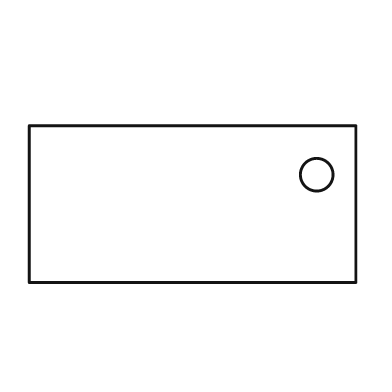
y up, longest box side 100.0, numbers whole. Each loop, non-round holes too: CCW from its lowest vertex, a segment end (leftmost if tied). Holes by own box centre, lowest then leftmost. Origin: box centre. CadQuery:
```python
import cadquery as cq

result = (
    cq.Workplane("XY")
    .moveTo(-50.0, -24.0)
    .lineTo(50.0, -24.0)
    .lineTo(50.0, 24.0)
    .lineTo(-50.0, 24.0)
    .close()
    .moveTo(38.0, 9.0)
    .circle(5.0)
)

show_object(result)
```